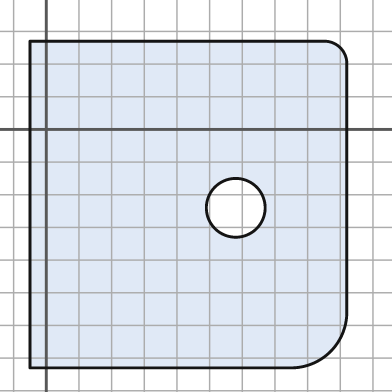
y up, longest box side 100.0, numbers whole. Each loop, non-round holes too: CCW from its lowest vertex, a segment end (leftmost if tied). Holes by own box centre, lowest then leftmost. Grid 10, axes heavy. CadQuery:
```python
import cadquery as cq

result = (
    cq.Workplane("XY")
    .moveTo(-5.0, -73.0)
    .lineTo(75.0, -73.0)
    .threePointArc((87.0, -68.0), (92.0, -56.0))
    .lineTo(92.0, 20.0)
    .threePointArc((90.0, 25.0), (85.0, 27.0))
    .lineTo(-5.0, 27.0)
    .close()
    .moveTo(58.0, -24.0)
    .circle(9.0)
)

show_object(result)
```